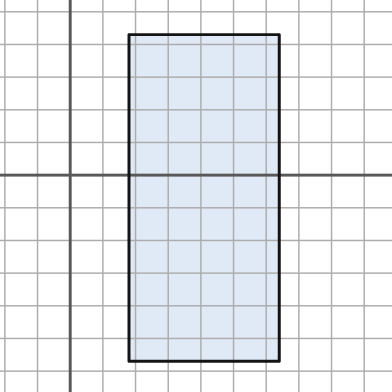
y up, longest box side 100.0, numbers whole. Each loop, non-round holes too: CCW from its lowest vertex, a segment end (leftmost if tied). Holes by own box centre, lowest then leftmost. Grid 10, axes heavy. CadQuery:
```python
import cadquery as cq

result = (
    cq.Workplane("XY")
    .moveTo(18.0, -57.0)
    .lineTo(64.0, -57.0)
    .lineTo(64.0, 43.0)
    .lineTo(18.0, 43.0)
    .close()
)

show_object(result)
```